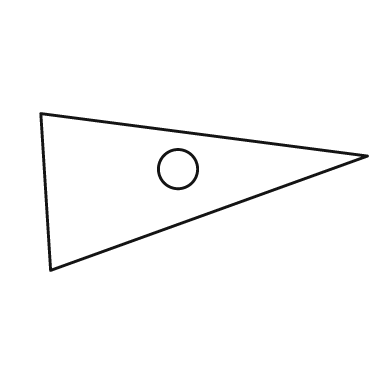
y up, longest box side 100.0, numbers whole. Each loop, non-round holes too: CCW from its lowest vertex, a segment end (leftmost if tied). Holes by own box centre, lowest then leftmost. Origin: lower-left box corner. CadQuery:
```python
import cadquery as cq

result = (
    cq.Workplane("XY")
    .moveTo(3.0, 0.0)
    .lineTo(100.0, 35.0)
    .lineTo(0.0, 48.0)
    .close()
    .moveTo(42.0, 31.0)
    .circle(6.0)
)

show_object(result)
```